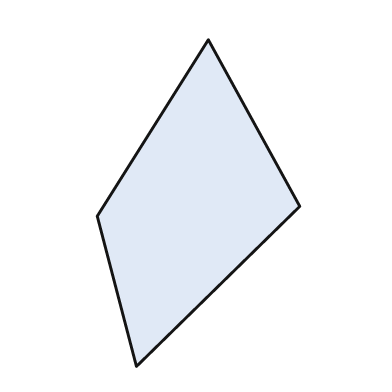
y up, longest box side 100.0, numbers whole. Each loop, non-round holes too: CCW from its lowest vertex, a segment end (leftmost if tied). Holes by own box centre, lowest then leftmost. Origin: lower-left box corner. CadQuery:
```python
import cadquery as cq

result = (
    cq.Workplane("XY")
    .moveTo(12.0, 0.0)
    .lineTo(62.0, 49.0)
    .lineTo(34.0, 100.0)
    .lineTo(0.0, 46.0)
    .close()
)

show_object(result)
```